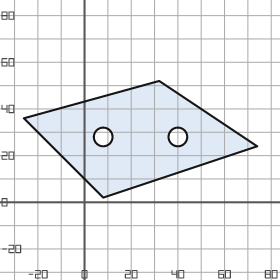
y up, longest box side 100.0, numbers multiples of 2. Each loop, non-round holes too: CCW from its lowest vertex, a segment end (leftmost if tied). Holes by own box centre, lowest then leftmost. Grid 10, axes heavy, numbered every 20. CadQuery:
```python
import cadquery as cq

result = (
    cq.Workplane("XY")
    .moveTo(8.0, 2.0)
    .lineTo(74.0, 24.0)
    .lineTo(32.0, 52.0)
    .lineTo(-26.0, 36.0)
    .close()
    .moveTo(8.0, 28.0)
    .circle(4.0)
    .moveTo(40.0, 28.0)
    .circle(4.0)
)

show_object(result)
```